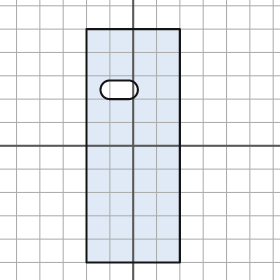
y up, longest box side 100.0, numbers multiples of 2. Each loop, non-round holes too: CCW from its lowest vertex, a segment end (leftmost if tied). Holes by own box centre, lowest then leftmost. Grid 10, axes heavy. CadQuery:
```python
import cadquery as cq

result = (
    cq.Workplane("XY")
    .moveTo(-20.0, -50.0)
    .lineTo(20.0, -50.0)
    .lineTo(20.0, 50.0)
    .lineTo(-20.0, 50.0)
    .close()
    .moveTo(-10.0, 20.0)
    .lineTo(-2.0, 20.0)
    .threePointArc((2.0, 24.0), (-2.0, 28.0))
    .lineTo(-10.0, 28.0)
    .threePointArc((-14.0, 24.0), (-10.0, 20.0))
    .close()
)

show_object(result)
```